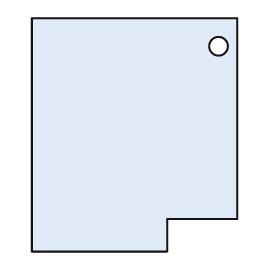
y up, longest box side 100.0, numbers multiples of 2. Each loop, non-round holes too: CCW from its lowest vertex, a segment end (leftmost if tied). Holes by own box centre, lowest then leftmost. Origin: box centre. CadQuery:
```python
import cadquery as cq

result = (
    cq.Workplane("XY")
    .moveTo(-44.0, -50.0)
    .lineTo(14.0, -50.0)
    .lineTo(14.0, -36.0)
    .lineTo(44.0, -36.0)
    .lineTo(44.0, 50.0)
    .lineTo(-44.0, 50.0)
    .close()
    .moveTo(36.0, 38.0)
    .circle(4.0)
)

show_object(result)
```